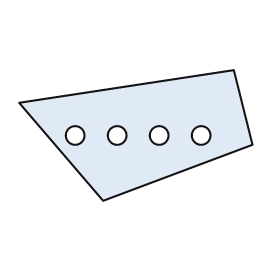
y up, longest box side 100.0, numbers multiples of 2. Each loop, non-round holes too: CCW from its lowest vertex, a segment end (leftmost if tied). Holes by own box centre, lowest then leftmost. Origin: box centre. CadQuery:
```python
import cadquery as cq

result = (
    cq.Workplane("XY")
    .moveTo(-14.0, -28.0)
    .lineTo(50.0, -4.0)
    .lineTo(42.0, 28.0)
    .lineTo(-50.0, 14.0)
    .close()
    .moveTo(-26.0, 0.0)
    .circle(4.0)
    .moveTo(-8.0, 0.0)
    .circle(4.0)
    .moveTo(10.0, 0.0)
    .circle(4.0)
    .moveTo(28.0, 0.0)
    .circle(4.0)
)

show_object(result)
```